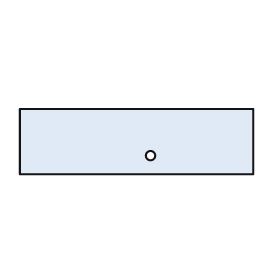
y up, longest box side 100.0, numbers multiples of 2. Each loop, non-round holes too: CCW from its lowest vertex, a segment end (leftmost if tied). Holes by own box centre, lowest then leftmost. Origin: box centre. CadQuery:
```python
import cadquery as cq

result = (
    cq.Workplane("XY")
    .moveTo(-50.0, -14.0)
    .lineTo(50.0, -14.0)
    .lineTo(50.0, 14.0)
    .lineTo(-50.0, 14.0)
    .close()
    .moveTo(6.0, -6.0)
    .circle(2.0)
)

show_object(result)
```